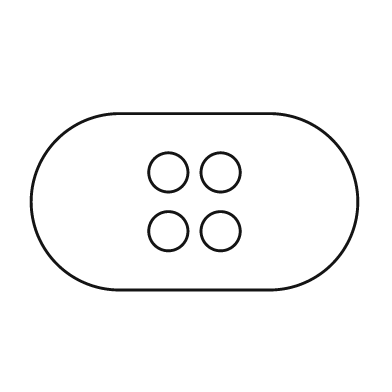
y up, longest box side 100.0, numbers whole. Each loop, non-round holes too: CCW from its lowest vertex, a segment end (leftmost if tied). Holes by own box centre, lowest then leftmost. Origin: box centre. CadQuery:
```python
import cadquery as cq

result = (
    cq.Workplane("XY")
    .moveTo(-23.0, -27.0)
    .lineTo(23.0, -27.0)
    .threePointArc((50.0, 0.0), (23.0, 27.0))
    .lineTo(-23.0, 27.0)
    .threePointArc((-50.0, 0.0), (-23.0, -27.0))
    .close()
    .moveTo(-8.0, -9.0)
    .circle(6.0)
    .moveTo(8.0, -9.0)
    .circle(6.0)
    .moveTo(-8.0, 9.0)
    .circle(6.0)
    .moveTo(8.0, 9.0)
    .circle(6.0)
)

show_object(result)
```